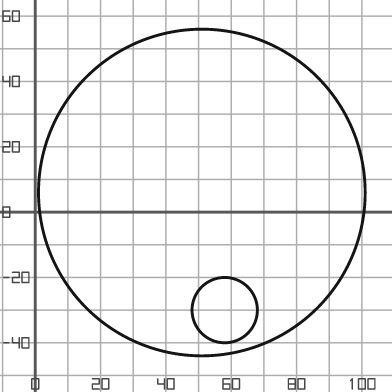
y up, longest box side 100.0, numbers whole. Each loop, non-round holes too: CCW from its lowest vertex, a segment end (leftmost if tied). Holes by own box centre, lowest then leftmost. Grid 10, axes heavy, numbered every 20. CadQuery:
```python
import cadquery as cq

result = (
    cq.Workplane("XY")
    .moveTo(51.0, 6.0)
    .circle(50.0)
    .moveTo(58.0, -30.0)
    .circle(10.0)
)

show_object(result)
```